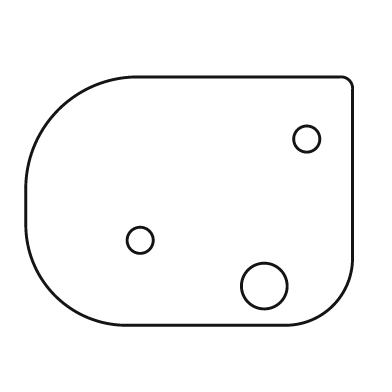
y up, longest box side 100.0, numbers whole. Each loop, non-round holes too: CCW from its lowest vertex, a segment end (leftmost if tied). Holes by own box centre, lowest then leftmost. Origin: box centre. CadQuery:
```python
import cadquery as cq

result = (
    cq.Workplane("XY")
    .moveTo(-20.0, -38.0)
    .lineTo(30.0, -38.0)
    .threePointArc((44.0, -32.0), (50.0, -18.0))
    .lineTo(50.0, 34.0)
    .threePointArc((49.0, 37.0), (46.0, 38.0))
    .lineTo(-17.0, 38.0)
    .threePointArc((-40.0, 28.0), (-50.0, 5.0))
    .lineTo(-50.0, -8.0)
    .threePointArc((-41.0, -29.0), (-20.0, -38.0))
    .close()
    .moveTo(23.0, -26.0)
    .circle(7.0)
    .moveTo(-15.0, -12.0)
    .circle(4.0)
    .moveTo(36.0, 19.0)
    .circle(4.0)
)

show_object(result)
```